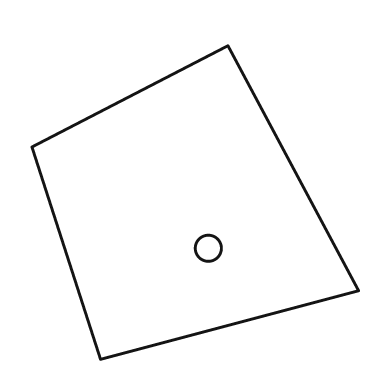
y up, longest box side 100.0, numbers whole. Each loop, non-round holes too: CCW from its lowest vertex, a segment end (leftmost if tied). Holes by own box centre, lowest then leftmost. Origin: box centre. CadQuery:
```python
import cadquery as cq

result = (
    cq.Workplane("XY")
    .moveTo(-29.0, -48.0)
    .lineTo(50.0, -27.0)
    .lineTo(10.0, 48.0)
    .lineTo(-50.0, 17.0)
    .close()
    .moveTo(4.0, -14.0)
    .circle(4.0)
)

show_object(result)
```